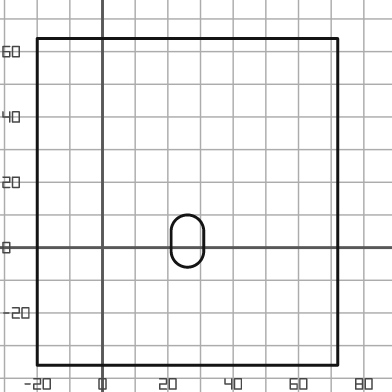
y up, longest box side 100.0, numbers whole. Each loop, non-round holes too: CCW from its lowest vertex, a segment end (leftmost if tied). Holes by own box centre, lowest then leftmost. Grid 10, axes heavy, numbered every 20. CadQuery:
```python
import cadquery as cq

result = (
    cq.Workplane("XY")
    .moveTo(-20.0, -36.0)
    .lineTo(72.0, -36.0)
    .lineTo(72.0, 64.0)
    .lineTo(-20.0, 64.0)
    .close()
    .moveTo(21.0, -1.0)
    .threePointArc((26.0, -6.0), (31.0, -1.0))
    .lineTo(31.0, 5.0)
    .threePointArc((26.0, 10.0), (21.0, 5.0))
    .close()
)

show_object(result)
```